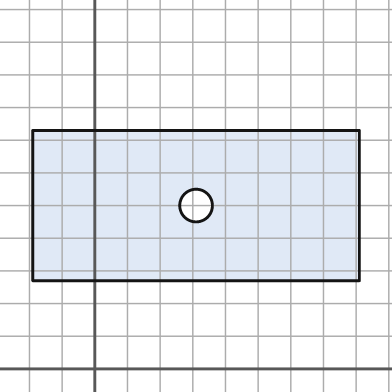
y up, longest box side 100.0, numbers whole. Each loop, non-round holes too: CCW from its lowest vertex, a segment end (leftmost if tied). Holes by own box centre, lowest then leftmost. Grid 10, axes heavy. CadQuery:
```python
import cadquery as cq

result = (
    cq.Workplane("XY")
    .moveTo(-19.0, 27.0)
    .lineTo(81.0, 27.0)
    .lineTo(81.0, 73.0)
    .lineTo(-19.0, 73.0)
    .close()
    .moveTo(31.0, 50.0)
    .circle(5.0)
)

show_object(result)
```